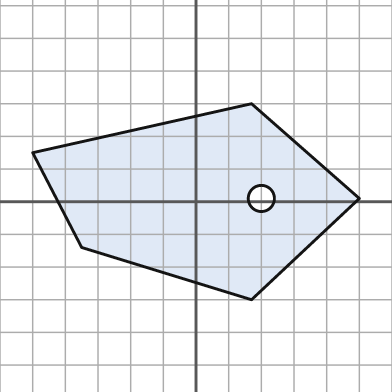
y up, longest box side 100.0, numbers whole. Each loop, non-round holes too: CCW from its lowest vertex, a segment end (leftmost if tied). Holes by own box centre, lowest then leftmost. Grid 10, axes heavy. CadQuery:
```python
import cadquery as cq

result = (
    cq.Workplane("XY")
    .moveTo(17.0, -30.0)
    .lineTo(50.0, 1.0)
    .lineTo(17.0, 30.0)
    .lineTo(-50.0, 15.0)
    .lineTo(-35.0, -14.0)
    .close()
    .moveTo(20.0, 1.0)
    .circle(4.0)
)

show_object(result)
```